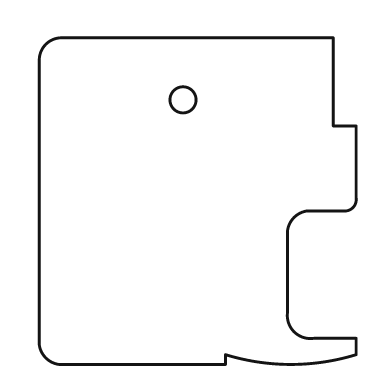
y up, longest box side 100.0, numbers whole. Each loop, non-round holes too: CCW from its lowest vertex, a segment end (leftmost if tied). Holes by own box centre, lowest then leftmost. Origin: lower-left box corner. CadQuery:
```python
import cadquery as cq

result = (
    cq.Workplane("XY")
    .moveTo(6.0, 0.0)
    .lineTo(57.0, 0.0)
    .lineTo(57.0, 3.0)
    .threePointArc((77.0, 0.0), (97.0, 3.0))
    .lineTo(97.0, 8.0)
    .lineTo(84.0, 8.0)
    .threePointArc((78.0, 10.0), (76.0, 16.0))
    .lineTo(76.0, 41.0)
    .threePointArc((78.0, 45.0), (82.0, 47.0))
    .lineTo(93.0, 47.0)
    .threePointArc((96.0, 48.0), (97.0, 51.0))
    .lineTo(97.0, 73.0)
    .lineTo(90.0, 73.0)
    .lineTo(90.0, 100.0)
    .lineTo(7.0, 100.0)
    .threePointArc((2.0, 98.0), (0.0, 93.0))
    .lineTo(0.0, 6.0)
    .threePointArc((2.0, 2.0), (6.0, 0.0))
    .close()
    .moveTo(44.0, 81.0)
    .circle(4.0)
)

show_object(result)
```